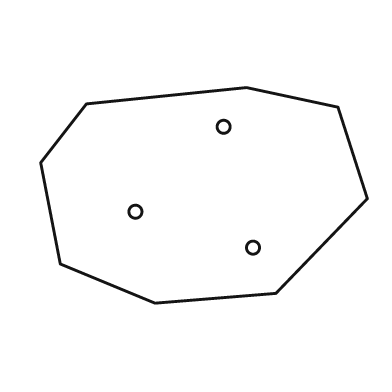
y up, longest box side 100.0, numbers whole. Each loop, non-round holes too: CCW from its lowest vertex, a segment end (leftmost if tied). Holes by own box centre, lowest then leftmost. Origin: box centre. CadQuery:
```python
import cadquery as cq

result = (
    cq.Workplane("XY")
    .moveTo(-15.0, -33.0)
    .lineTo(22.0, -30.0)
    .lineTo(50.0, -1.0)
    .lineTo(41.0, 27.0)
    .lineTo(13.0, 33.0)
    .lineTo(-36.0, 28.0)
    .lineTo(-50.0, 10.0)
    .lineTo(-44.0, -21.0)
    .close()
    .moveTo(15.0, -16.0)
    .circle(2.0)
    .moveTo(-21.0, -5.0)
    .circle(2.0)
    .moveTo(6.0, 21.0)
    .circle(2.0)
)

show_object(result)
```